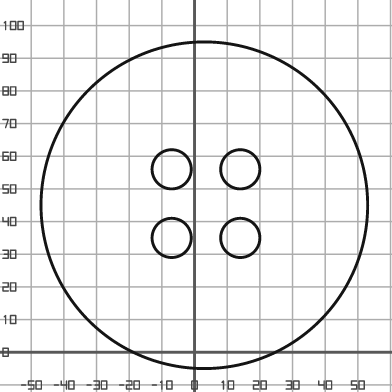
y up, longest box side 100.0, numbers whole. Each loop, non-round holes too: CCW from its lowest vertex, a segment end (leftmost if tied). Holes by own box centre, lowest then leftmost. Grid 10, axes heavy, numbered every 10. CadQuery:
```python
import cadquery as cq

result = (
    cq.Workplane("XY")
    .moveTo(3.0, 45.0)
    .circle(50.0)
    .moveTo(-7.0, 35.0)
    .circle(6.0)
    .moveTo(14.0, 35.0)
    .circle(6.0)
    .moveTo(-7.0, 56.0)
    .circle(6.0)
    .moveTo(14.0, 56.0)
    .circle(6.0)
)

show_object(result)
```